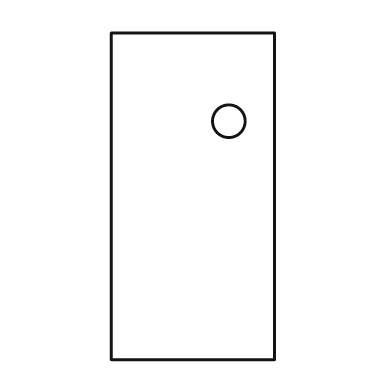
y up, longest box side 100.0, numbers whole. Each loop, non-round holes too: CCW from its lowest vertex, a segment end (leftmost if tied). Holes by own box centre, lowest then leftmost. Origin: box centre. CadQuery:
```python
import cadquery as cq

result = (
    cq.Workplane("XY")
    .moveTo(-25.0, -50.0)
    .lineTo(25.0, -50.0)
    .lineTo(25.0, 50.0)
    .lineTo(-25.0, 50.0)
    .close()
    .moveTo(11.0, 23.0)
    .circle(5.0)
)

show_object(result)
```